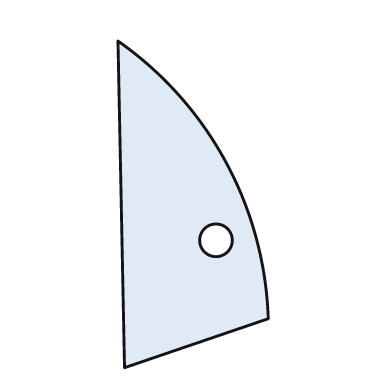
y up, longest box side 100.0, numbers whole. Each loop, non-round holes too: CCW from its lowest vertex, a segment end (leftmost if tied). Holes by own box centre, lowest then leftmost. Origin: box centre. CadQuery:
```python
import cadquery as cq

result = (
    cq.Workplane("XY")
    .moveTo(-21.0, -50.0)
    .lineTo(23.0, -35.0)
    .threePointArc((10.0, 13.0), (-23.0, 50.0))
    .close()
    .moveTo(7.0, -11.0)
    .circle(5.0)
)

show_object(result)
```